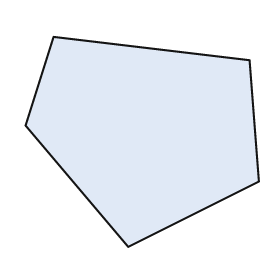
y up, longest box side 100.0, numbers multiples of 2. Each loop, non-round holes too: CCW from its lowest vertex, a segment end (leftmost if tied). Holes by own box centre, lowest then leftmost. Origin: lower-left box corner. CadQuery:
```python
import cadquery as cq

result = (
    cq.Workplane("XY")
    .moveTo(44.0, 0.0)
    .lineTo(100.0, 28.0)
    .lineTo(96.0, 80.0)
    .lineTo(12.0, 90.0)
    .lineTo(0.0, 52.0)
    .close()
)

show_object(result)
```